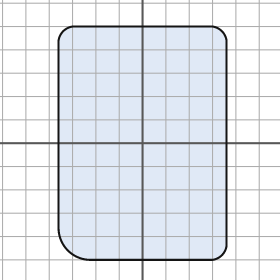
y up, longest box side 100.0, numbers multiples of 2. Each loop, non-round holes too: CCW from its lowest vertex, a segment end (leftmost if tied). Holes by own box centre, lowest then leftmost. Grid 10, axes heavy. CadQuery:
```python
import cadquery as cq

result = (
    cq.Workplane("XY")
    .moveTo(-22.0, -50.0)
    .lineTo(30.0, -50.0)
    .threePointArc((34.0, -48.0), (36.0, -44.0))
    .lineTo(36.0, 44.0)
    .threePointArc((34.0, 48.0), (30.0, 50.0))
    .lineTo(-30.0, 50.0)
    .threePointArc((-34.0, 48.0), (-36.0, 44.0))
    .lineTo(-36.0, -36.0)
    .threePointArc((-32.0, -46.0), (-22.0, -50.0))
    .close()
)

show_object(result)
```